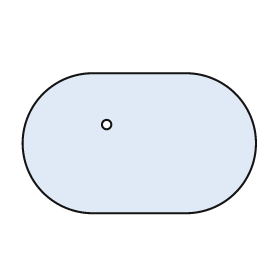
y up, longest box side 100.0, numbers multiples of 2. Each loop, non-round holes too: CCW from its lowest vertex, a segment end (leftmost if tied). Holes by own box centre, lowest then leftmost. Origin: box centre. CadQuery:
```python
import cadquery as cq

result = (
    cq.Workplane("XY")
    .moveTo(-20.0, -30.0)
    .lineTo(20.0, -30.0)
    .threePointArc((50.0, 0.0), (20.0, 30.0))
    .lineTo(-20.0, 30.0)
    .threePointArc((-50.0, 0.0), (-20.0, -30.0))
    .close()
    .moveTo(-14.0, 8.0)
    .circle(2.0)
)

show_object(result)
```